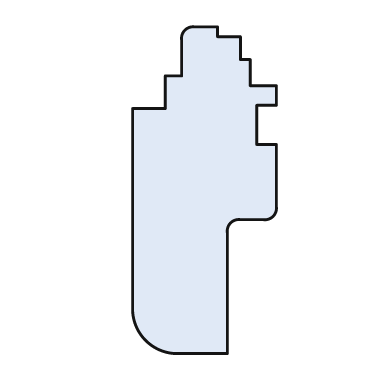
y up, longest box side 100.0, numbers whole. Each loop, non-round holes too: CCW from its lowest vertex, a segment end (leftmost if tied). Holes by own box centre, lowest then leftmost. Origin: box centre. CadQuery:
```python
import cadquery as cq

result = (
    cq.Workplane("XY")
    .moveTo(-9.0, -50.0)
    .lineTo(7.0, -50.0)
    .lineTo(7.0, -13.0)
    .threePointArc((8.0, -10.0), (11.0, -9.0))
    .lineTo(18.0, -9.0)
    .threePointArc((21.0, -8.0), (22.0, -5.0))
    .lineTo(22.0, 14.0)
    .lineTo(16.0, 14.0)
    .lineTo(16.0, 26.0)
    .lineTo(22.0, 26.0)
    .lineTo(22.0, 32.0)
    .lineTo(14.0, 32.0)
    .lineTo(14.0, 40.0)
    .lineTo(11.0, 40.0)
    .lineTo(11.0, 47.0)
    .lineTo(4.0, 47.0)
    .lineTo(4.0, 50.0)
    .lineTo(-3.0, 50.0)
    .threePointArc((-6.0, 49.0), (-7.0, 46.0))
    .lineTo(-7.0, 35.0)
    .lineTo(-12.0, 35.0)
    .lineTo(-12.0, 25.0)
    .lineTo(-22.0, 25.0)
    .lineTo(-22.0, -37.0)
    .threePointArc((-18.0, -46.0), (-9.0, -50.0))
    .close()
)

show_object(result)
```